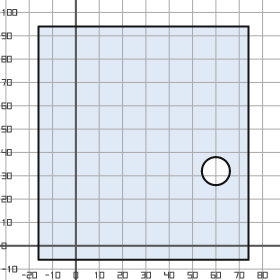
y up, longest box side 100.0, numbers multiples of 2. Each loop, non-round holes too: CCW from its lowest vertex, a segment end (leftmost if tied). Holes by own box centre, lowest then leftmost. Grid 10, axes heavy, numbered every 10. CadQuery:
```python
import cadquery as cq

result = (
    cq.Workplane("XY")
    .moveTo(-16.0, -6.0)
    .lineTo(74.0, -6.0)
    .lineTo(74.0, 94.0)
    .lineTo(-16.0, 94.0)
    .close()
    .moveTo(60.0, 32.0)
    .circle(6.0)
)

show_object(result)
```